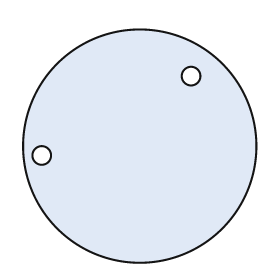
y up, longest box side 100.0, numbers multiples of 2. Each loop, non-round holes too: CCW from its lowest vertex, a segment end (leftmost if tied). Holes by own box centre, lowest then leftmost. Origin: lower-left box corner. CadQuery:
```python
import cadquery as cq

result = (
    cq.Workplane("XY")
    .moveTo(50.0, 50.0)
    .circle(50.0)
    .moveTo(8.0, 46.0)
    .circle(4.0)
    .moveTo(72.0, 80.0)
    .circle(4.0)
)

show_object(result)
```